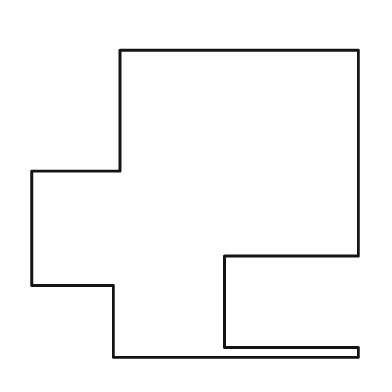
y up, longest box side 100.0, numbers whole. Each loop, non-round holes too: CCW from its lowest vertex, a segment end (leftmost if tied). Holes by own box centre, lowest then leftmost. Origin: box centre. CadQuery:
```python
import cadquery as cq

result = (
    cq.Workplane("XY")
    .moveTo(-25.0, -47.0)
    .lineTo(50.0, -47.0)
    .lineTo(50.0, -44.0)
    .lineTo(9.0, -44.0)
    .lineTo(9.0, -16.0)
    .lineTo(50.0, -16.0)
    .lineTo(50.0, 47.0)
    .lineTo(-23.0, 47.0)
    .lineTo(-23.0, 10.0)
    .lineTo(-50.0, 10.0)
    .lineTo(-50.0, -25.0)
    .lineTo(-25.0, -25.0)
    .close()
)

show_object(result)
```